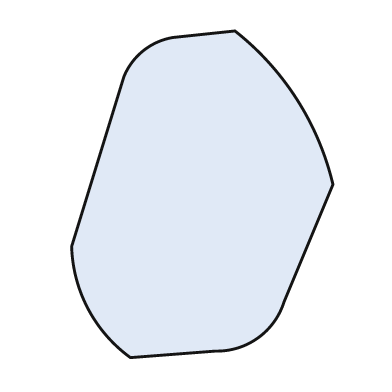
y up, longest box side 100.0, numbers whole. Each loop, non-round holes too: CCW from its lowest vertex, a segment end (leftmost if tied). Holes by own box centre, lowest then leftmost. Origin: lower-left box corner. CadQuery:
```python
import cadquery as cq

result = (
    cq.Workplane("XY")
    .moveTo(18.0, 0.0)
    .lineTo(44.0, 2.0)
    .threePointArc((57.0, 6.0), (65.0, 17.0))
    .lineTo(80.0, 53.0)
    .threePointArc((69.0, 79.0), (50.0, 100.0))
    .lineTo(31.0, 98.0)
    .threePointArc((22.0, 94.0), (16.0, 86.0))
    .lineTo(0.0, 34.0)
    .threePointArc((5.0, 15.0), (18.0, 0.0))
    .close()
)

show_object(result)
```